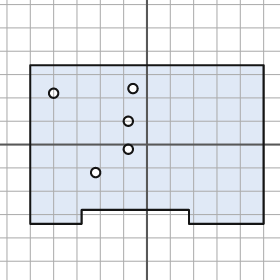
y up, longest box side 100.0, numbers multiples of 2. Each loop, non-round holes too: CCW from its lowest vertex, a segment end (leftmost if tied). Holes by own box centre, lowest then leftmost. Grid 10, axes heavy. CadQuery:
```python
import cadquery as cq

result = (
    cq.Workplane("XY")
    .moveTo(-50.0, -34.0)
    .lineTo(-28.0, -34.0)
    .lineTo(-28.0, -28.0)
    .lineTo(18.0, -28.0)
    .lineTo(18.0, -34.0)
    .lineTo(50.0, -34.0)
    .lineTo(50.0, 34.0)
    .lineTo(-50.0, 34.0)
    .close()
    .moveTo(-22.0, -12.0)
    .circle(2.0)
    .moveTo(-8.0, -2.0)
    .circle(2.0)
    .moveTo(-8.0, 10.0)
    .circle(2.0)
    .moveTo(-40.0, 22.0)
    .circle(2.0)
    .moveTo(-6.0, 24.0)
    .circle(2.0)
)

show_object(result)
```